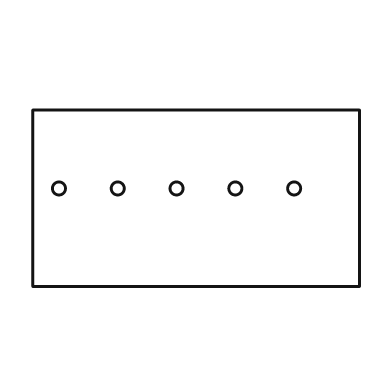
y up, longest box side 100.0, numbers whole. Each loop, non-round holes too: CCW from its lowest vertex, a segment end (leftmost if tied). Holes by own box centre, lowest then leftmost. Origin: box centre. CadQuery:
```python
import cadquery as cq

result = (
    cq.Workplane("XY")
    .moveTo(-50.0, -27.0)
    .lineTo(50.0, -27.0)
    .lineTo(50.0, 27.0)
    .lineTo(-50.0, 27.0)
    .close()
    .moveTo(-42.0, 3.0)
    .circle(2.0)
    .moveTo(-24.0, 3.0)
    .circle(2.0)
    .moveTo(-6.0, 3.0)
    .circle(2.0)
    .moveTo(12.0, 3.0)
    .circle(2.0)
    .moveTo(30.0, 3.0)
    .circle(2.0)
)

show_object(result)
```